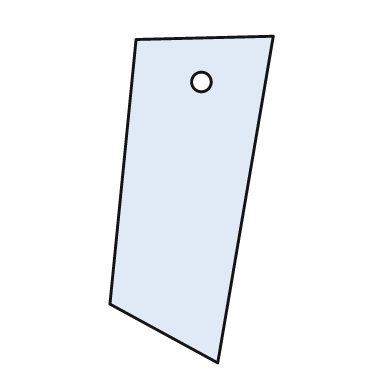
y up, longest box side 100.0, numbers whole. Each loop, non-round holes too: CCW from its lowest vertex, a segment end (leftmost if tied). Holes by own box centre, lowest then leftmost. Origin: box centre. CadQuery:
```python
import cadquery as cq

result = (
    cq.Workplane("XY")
    .moveTo(8.0, -50.0)
    .lineTo(25.0, 50.0)
    .lineTo(-17.0, 49.0)
    .lineTo(-25.0, -32.0)
    .close()
    .moveTo(3.0, 36.0)
    .circle(3.0)
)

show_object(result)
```